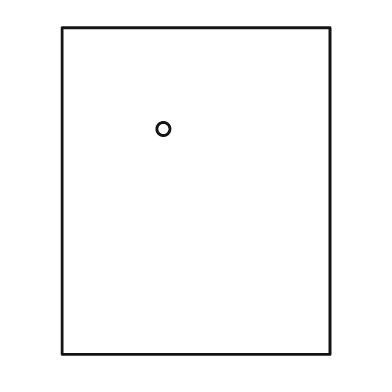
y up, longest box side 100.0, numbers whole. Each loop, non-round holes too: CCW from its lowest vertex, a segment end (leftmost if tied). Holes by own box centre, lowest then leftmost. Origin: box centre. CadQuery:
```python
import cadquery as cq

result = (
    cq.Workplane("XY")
    .moveTo(-41.0, -50.0)
    .lineTo(41.0, -50.0)
    .lineTo(41.0, 50.0)
    .lineTo(-41.0, 50.0)
    .close()
    .moveTo(-10.0, 19.0)
    .circle(2.0)
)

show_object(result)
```